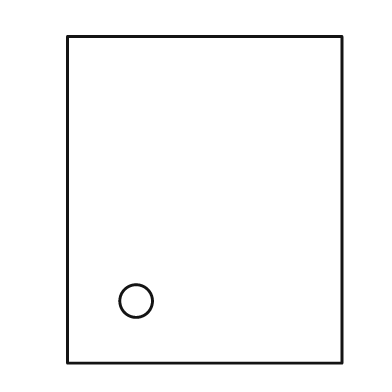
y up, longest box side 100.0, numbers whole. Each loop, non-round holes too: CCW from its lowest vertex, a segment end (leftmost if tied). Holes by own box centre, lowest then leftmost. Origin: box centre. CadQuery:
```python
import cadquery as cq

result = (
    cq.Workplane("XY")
    .moveTo(-42.0, -50.0)
    .lineTo(42.0, -50.0)
    .lineTo(42.0, 50.0)
    .lineTo(-42.0, 50.0)
    .close()
    .moveTo(-21.0, -31.0)
    .circle(5.0)
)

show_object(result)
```